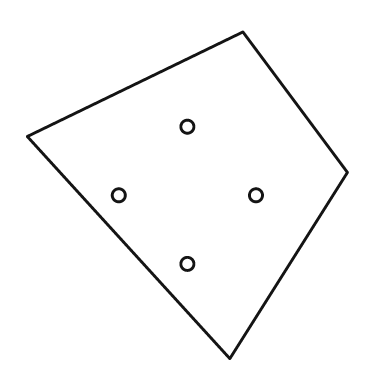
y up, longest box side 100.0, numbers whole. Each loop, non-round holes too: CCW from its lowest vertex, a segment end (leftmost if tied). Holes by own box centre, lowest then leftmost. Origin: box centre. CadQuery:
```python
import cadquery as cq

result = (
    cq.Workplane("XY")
    .moveTo(13.0, -50.0)
    .lineTo(49.0, 7.0)
    .lineTo(17.0, 50.0)
    .lineTo(-49.0, 18.0)
    .close()
    .moveTo(0.0, -21.0)
    .circle(2.0)
    .moveTo(-21.0, 0.0)
    .circle(2.0)
    .moveTo(21.0, 0.0)
    .circle(2.0)
    .moveTo(0.0, 21.0)
    .circle(2.0)
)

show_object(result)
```